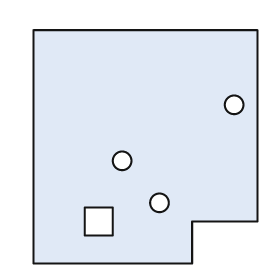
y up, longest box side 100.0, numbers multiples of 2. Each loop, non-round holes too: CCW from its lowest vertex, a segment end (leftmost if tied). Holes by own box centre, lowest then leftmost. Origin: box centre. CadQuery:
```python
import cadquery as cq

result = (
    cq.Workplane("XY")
    .moveTo(-48.0, -50.0)
    .lineTo(20.0, -50.0)
    .lineTo(20.0, -32.0)
    .lineTo(48.0, -32.0)
    .lineTo(48.0, 50.0)
    .lineTo(-48.0, 50.0)
    .close()
    .moveTo(-26.0, -38.0)
    .lineTo(-14.0, -38.0)
    .lineTo(-14.0, -26.0)
    .lineTo(-26.0, -26.0)
    .close()
    .moveTo(6.0, -24.0)
    .circle(4.0)
    .moveTo(-10.0, -6.0)
    .circle(4.0)
    .moveTo(38.0, 18.0)
    .circle(4.0)
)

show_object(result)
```